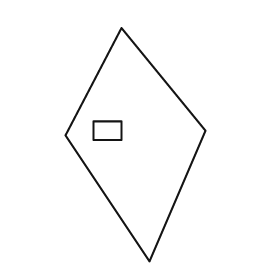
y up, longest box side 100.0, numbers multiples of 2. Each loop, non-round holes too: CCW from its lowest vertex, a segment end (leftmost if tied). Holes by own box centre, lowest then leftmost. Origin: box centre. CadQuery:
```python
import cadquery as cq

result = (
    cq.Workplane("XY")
    .moveTo(6.0, -50.0)
    .lineTo(30.0, 6.0)
    .lineTo(-6.0, 50.0)
    .lineTo(-30.0, 4.0)
    .close()
    .moveTo(-18.0, 2.0)
    .lineTo(-6.0, 2.0)
    .lineTo(-6.0, 10.0)
    .lineTo(-18.0, 10.0)
    .close()
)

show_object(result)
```